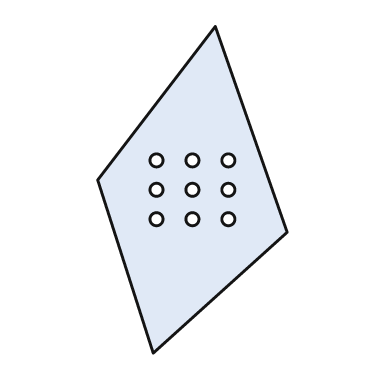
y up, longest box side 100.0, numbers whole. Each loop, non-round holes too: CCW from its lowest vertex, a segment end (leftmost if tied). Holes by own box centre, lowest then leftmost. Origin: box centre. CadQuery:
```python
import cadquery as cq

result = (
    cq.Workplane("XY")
    .moveTo(-12.0, -50.0)
    .lineTo(29.0, -13.0)
    .lineTo(7.0, 50.0)
    .lineTo(-29.0, 3.0)
    .close()
    .moveTo(-11.0, -9.0)
    .circle(2.0)
    .moveTo(0.0, -9.0)
    .circle(2.0)
    .moveTo(11.0, -9.0)
    .circle(2.0)
    .moveTo(-11.0, 0.0)
    .circle(2.0)
    .moveTo(0.0, 0.0)
    .circle(2.0)
    .moveTo(11.0, 0.0)
    .circle(2.0)
    .moveTo(-11.0, 9.0)
    .circle(2.0)
    .moveTo(0.0, 9.0)
    .circle(2.0)
    .moveTo(11.0, 9.0)
    .circle(2.0)
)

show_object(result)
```